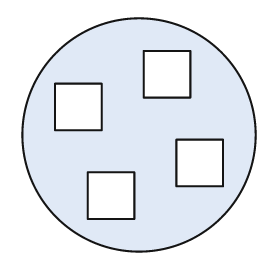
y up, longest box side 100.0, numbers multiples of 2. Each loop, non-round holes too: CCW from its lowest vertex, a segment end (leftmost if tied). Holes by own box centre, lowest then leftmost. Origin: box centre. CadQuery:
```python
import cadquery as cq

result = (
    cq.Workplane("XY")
    .moveTo(0.0, 0.0)
    .circle(50.0)
    .moveTo(-22.0, -36.0)
    .lineTo(-2.0, -36.0)
    .lineTo(-2.0, -16.0)
    .lineTo(-22.0, -16.0)
    .close()
    .moveTo(16.0, -22.0)
    .lineTo(36.0, -22.0)
    .lineTo(36.0, -2.0)
    .lineTo(16.0, -2.0)
    .close()
    .moveTo(-36.0, 2.0)
    .lineTo(-16.0, 2.0)
    .lineTo(-16.0, 22.0)
    .lineTo(-36.0, 22.0)
    .close()
    .moveTo(2.0, 16.0)
    .lineTo(22.0, 16.0)
    .lineTo(22.0, 36.0)
    .lineTo(2.0, 36.0)
    .close()
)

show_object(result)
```